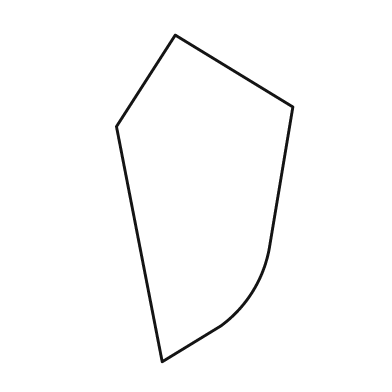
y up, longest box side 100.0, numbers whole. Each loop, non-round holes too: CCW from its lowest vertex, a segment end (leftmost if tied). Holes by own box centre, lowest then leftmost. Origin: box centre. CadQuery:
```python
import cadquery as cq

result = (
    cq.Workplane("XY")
    .moveTo(-13.0, -50.0)
    .lineTo(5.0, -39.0)
    .threePointArc((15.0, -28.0), (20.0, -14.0))
    .lineTo(27.0, 28.0)
    .lineTo(-9.0, 50.0)
    .lineTo(-27.0, 22.0)
    .close()
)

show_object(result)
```